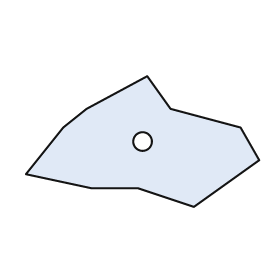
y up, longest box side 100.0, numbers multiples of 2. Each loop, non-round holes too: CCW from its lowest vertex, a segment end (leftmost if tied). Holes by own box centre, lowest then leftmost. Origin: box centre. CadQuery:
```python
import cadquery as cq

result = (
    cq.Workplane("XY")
    .moveTo(22.0, -28.0)
    .lineTo(50.0, -8.0)
    .lineTo(42.0, 6.0)
    .lineTo(12.0, 14.0)
    .lineTo(2.0, 28.0)
    .lineTo(-24.0, 14.0)
    .lineTo(-34.0, 6.0)
    .lineTo(-50.0, -14.0)
    .lineTo(-22.0, -20.0)
    .lineTo(-2.0, -20.0)
    .close()
    .moveTo(0.0, 0.0)
    .circle(4.0)
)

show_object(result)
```